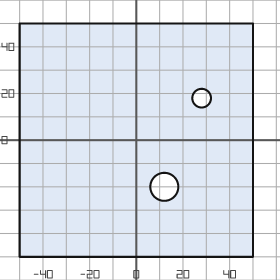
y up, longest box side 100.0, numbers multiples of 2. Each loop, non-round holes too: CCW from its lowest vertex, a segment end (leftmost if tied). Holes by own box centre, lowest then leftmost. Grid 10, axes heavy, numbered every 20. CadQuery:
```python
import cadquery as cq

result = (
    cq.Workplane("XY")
    .moveTo(-50.0, -50.0)
    .lineTo(50.0, -50.0)
    .lineTo(50.0, 50.0)
    .lineTo(-50.0, 50.0)
    .close()
    .moveTo(12.0, -20.0)
    .circle(6.0)
    .moveTo(28.0, 18.0)
    .circle(4.0)
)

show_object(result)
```